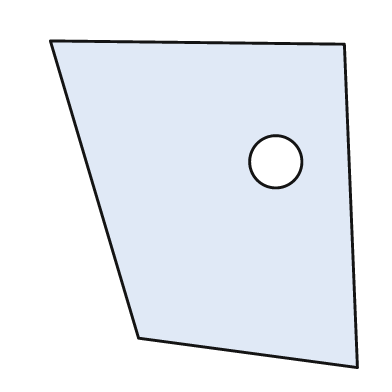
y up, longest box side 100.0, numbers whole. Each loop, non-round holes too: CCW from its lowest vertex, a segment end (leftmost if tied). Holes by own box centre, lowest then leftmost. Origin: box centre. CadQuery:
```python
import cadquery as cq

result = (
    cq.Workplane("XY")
    .moveTo(47.0, -50.0)
    .lineTo(43.0, 49.0)
    .lineTo(-47.0, 50.0)
    .lineTo(-20.0, -41.0)
    .close()
    .moveTo(22.0, 13.0)
    .circle(8.0)
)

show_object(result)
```